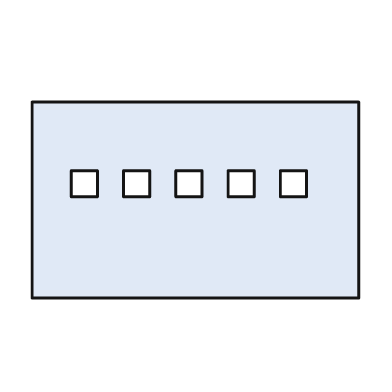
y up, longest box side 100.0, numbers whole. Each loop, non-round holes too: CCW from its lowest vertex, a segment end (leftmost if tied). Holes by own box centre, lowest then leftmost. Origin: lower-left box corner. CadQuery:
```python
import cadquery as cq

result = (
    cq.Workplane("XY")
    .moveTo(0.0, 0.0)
    .lineTo(100.0, 0.0)
    .lineTo(100.0, 60.0)
    .lineTo(0.0, 60.0)
    .close()
    .moveTo(12.0, 31.0)
    .lineTo(20.0, 31.0)
    .lineTo(20.0, 39.0)
    .lineTo(12.0, 39.0)
    .close()
    .moveTo(28.0, 31.0)
    .lineTo(36.0, 31.0)
    .lineTo(36.0, 39.0)
    .lineTo(28.0, 39.0)
    .close()
    .moveTo(44.0, 31.0)
    .lineTo(52.0, 31.0)
    .lineTo(52.0, 39.0)
    .lineTo(44.0, 39.0)
    .close()
    .moveTo(60.0, 31.0)
    .lineTo(68.0, 31.0)
    .lineTo(68.0, 39.0)
    .lineTo(60.0, 39.0)
    .close()
    .moveTo(76.0, 31.0)
    .lineTo(84.0, 31.0)
    .lineTo(84.0, 39.0)
    .lineTo(76.0, 39.0)
    .close()
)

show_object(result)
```